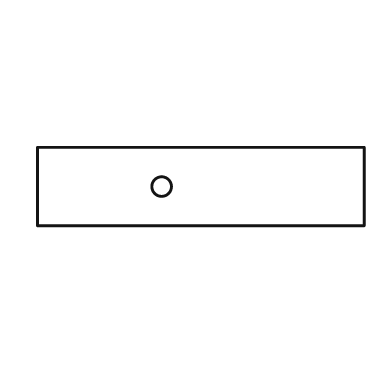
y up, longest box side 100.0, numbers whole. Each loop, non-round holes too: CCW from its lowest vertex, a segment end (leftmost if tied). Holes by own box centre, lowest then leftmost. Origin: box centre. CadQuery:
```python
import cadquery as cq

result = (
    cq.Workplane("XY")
    .moveTo(-50.0, -12.0)
    .lineTo(50.0, -12.0)
    .lineTo(50.0, 12.0)
    .lineTo(-50.0, 12.0)
    .close()
    .moveTo(-12.0, 0.0)
    .circle(3.0)
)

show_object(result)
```